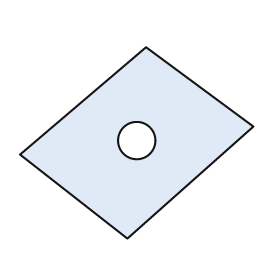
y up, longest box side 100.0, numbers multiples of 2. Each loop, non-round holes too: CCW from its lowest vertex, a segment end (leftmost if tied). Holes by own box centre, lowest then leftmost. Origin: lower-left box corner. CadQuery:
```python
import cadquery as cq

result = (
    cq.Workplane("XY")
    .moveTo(46.0, 0.0)
    .lineTo(100.0, 48.0)
    .lineTo(54.0, 82.0)
    .lineTo(0.0, 36.0)
    .close()
    .moveTo(50.0, 42.0)
    .circle(8.0)
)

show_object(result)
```